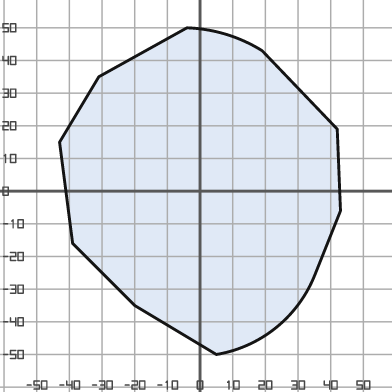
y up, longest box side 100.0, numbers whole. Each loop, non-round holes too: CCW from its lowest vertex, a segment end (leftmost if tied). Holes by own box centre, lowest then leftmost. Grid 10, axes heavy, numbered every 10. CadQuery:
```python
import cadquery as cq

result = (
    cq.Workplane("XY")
    .moveTo(5.0, -50.0)
    .threePointArc((23.0, -42.0), (35.0, -26.0))
    .lineTo(43.0, -6.0)
    .lineTo(42.0, 19.0)
    .lineTo(19.0, 43.0)
    .threePointArc((8.0, 48.0), (-4.0, 50.0))
    .lineTo(-31.0, 35.0)
    .lineTo(-43.0, 15.0)
    .lineTo(-39.0, -16.0)
    .lineTo(-20.0, -35.0)
    .close()
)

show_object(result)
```